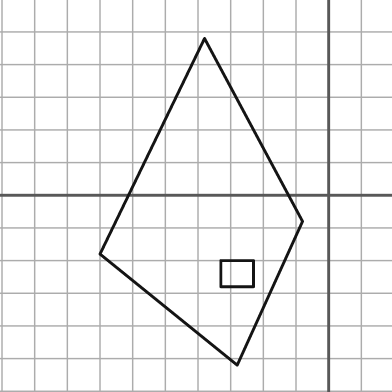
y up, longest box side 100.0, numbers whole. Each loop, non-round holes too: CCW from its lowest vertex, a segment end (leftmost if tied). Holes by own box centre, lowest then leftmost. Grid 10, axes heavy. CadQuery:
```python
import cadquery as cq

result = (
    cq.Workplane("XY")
    .moveTo(-28.0, -52.0)
    .lineTo(-8.0, -8.0)
    .lineTo(-38.0, 48.0)
    .lineTo(-70.0, -18.0)
    .close()
    .moveTo(-33.0, -28.0)
    .lineTo(-23.0, -28.0)
    .lineTo(-23.0, -20.0)
    .lineTo(-33.0, -20.0)
    .close()
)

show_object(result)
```